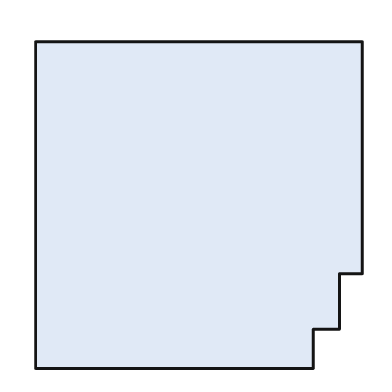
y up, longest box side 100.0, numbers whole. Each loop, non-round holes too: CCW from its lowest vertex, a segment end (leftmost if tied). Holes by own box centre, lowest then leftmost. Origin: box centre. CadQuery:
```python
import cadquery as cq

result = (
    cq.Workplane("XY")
    .moveTo(-50.0, -50.0)
    .lineTo(35.0, -50.0)
    .lineTo(35.0, -38.0)
    .lineTo(43.0, -38.0)
    .lineTo(43.0, -21.0)
    .lineTo(50.0, -21.0)
    .lineTo(50.0, 50.0)
    .lineTo(-50.0, 50.0)
    .close()
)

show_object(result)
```